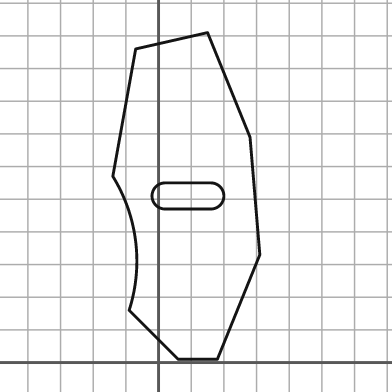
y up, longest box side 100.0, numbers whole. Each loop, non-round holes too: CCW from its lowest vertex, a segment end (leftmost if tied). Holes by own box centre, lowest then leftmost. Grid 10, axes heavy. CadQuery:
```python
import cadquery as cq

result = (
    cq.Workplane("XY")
    .moveTo(6.0, 1.0)
    .lineTo(18.0, 1.0)
    .lineTo(31.0, 33.0)
    .lineTo(28.0, 69.0)
    .lineTo(15.0, 101.0)
    .lineTo(-7.0, 96.0)
    .lineTo(-14.0, 57.0)
    .threePointArc((-7.0, 37.0), (-9.0, 16.0))
    .close()
    .moveTo(2.0, 47.0)
    .lineTo(16.0, 47.0)
    .threePointArc((20.0, 51.0), (16.0, 55.0))
    .lineTo(2.0, 55.0)
    .threePointArc((-2.0, 51.0), (2.0, 47.0))
    .close()
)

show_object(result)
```